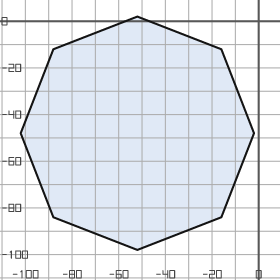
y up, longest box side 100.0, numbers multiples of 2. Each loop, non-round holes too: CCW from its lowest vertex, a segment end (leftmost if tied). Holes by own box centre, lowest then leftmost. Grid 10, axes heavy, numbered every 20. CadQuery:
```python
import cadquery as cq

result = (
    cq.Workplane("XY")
    .moveTo(-52.0, -98.0)
    .lineTo(-16.0, -84.0)
    .lineTo(-2.0, -48.0)
    .lineTo(-16.0, -12.0)
    .lineTo(-52.0, 2.0)
    .lineTo(-88.0, -12.0)
    .lineTo(-102.0, -48.0)
    .lineTo(-88.0, -84.0)
    .close()
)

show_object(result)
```